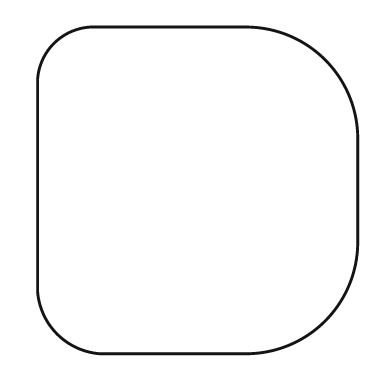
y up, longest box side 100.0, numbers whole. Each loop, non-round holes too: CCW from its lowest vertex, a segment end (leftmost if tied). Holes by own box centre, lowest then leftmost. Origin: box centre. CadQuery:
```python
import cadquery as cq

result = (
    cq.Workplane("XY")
    .moveTo(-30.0, -50.0)
    .lineTo(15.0, -50.0)
    .threePointArc((39.0, -40.0), (49.0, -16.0))
    .lineTo(49.0, 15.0)
    .threePointArc((39.0, 40.0), (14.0, 50.0))
    .lineTo(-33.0, 50.0)
    .threePointArc((-44.0, 45.0), (-49.0, 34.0))
    .lineTo(-49.0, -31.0)
    .threePointArc((-43.0, -44.0), (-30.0, -50.0))
    .close()
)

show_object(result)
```